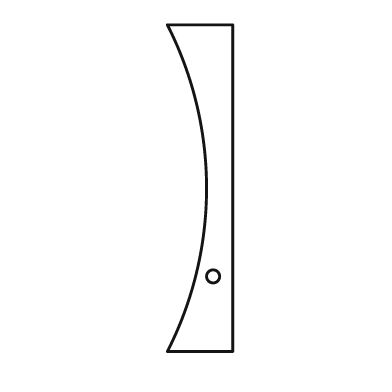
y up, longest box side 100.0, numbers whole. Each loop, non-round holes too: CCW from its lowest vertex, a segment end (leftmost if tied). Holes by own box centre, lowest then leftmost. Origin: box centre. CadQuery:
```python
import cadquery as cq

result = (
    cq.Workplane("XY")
    .moveTo(-10.0, -50.0)
    .lineTo(10.0, -50.0)
    .lineTo(10.0, 50.0)
    .lineTo(-10.0, 50.0)
    .threePointArc((2.0, 0.0), (-10.0, -50.0))
    .close()
    .moveTo(4.0, -27.0)
    .circle(2.0)
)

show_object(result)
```